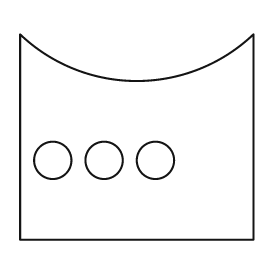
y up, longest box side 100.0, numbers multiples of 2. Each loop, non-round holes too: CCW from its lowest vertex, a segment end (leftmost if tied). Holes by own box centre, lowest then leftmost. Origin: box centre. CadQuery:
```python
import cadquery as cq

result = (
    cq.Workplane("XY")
    .moveTo(-50.0, -44.0)
    .lineTo(50.0, -44.0)
    .lineTo(50.0, 44.0)
    .threePointArc((0.0, 24.0), (-50.0, 44.0))
    .close()
    .moveTo(-36.0, -10.0)
    .circle(8.0)
    .moveTo(-14.0, -10.0)
    .circle(8.0)
    .moveTo(8.0, -10.0)
    .circle(8.0)
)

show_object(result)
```